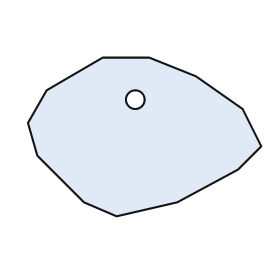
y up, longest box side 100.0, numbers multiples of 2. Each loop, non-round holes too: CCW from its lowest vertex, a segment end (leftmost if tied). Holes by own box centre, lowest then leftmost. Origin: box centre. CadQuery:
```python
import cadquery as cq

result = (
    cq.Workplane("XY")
    .moveTo(-12.0, -34.0)
    .lineTo(14.0, -28.0)
    .lineTo(40.0, -14.0)
    .lineTo(50.0, -4.0)
    .lineTo(42.0, 12.0)
    .lineTo(22.0, 26.0)
    .lineTo(2.0, 34.0)
    .lineTo(-18.0, 34.0)
    .lineTo(-42.0, 20.0)
    .lineTo(-50.0, 6.0)
    .lineTo(-46.0, -8.0)
    .lineTo(-26.0, -28.0)
    .close()
    .moveTo(-4.0, 16.0)
    .circle(4.0)
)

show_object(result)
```